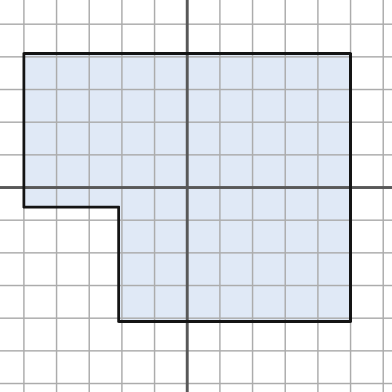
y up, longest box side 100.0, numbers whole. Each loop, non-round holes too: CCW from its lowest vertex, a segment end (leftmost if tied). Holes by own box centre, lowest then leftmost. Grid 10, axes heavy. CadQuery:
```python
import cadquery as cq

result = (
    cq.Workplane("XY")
    .moveTo(-21.0, -41.0)
    .lineTo(50.0, -41.0)
    .lineTo(50.0, 41.0)
    .lineTo(-50.0, 41.0)
    .lineTo(-50.0, -6.0)
    .lineTo(-21.0, -6.0)
    .close()
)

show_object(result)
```